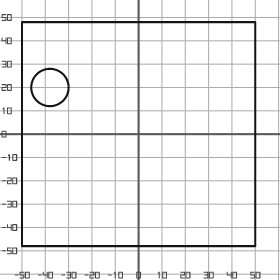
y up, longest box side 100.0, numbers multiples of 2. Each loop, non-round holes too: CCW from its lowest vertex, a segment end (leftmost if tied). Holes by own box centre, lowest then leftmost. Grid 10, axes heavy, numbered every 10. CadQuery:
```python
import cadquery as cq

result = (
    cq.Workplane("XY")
    .moveTo(-50.0, -48.0)
    .lineTo(50.0, -48.0)
    .lineTo(50.0, 48.0)
    .lineTo(-50.0, 48.0)
    .close()
    .moveTo(-38.0, 20.0)
    .circle(8.0)
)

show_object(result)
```